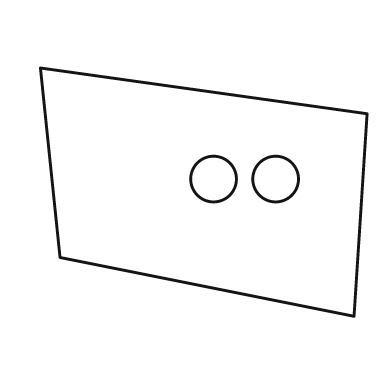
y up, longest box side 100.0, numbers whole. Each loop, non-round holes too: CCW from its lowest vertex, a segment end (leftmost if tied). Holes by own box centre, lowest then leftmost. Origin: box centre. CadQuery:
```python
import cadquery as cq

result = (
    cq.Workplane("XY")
    .moveTo(46.0, -38.0)
    .lineTo(50.0, 24.0)
    .lineTo(-50.0, 38.0)
    .lineTo(-44.0, -20.0)
    .close()
    .moveTo(3.0, 4.0)
    .circle(7.0)
    .moveTo(22.0, 4.0)
    .circle(7.0)
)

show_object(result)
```